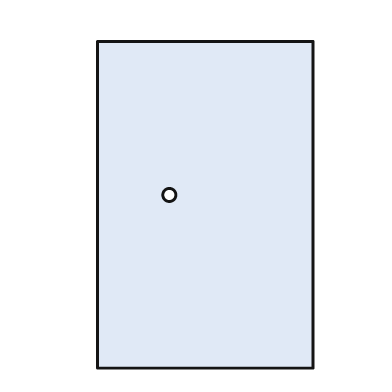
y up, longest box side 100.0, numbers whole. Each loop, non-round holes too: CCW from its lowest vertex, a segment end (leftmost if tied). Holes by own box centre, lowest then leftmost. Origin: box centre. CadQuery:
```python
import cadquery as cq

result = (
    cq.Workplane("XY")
    .moveTo(-33.0, -50.0)
    .lineTo(33.0, -50.0)
    .lineTo(33.0, 50.0)
    .lineTo(-33.0, 50.0)
    .close()
    .moveTo(-11.0, 3.0)
    .circle(2.0)
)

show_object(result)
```